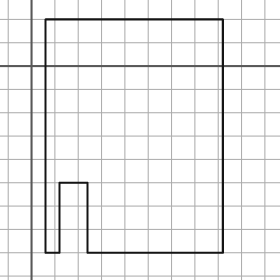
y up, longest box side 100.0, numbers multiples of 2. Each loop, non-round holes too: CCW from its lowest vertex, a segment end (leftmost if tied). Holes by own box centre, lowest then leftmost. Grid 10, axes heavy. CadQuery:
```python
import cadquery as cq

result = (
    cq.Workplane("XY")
    .moveTo(6.0, -80.0)
    .lineTo(12.0, -80.0)
    .lineTo(12.0, -50.0)
    .lineTo(24.0, -50.0)
    .lineTo(24.0, -80.0)
    .lineTo(82.0, -80.0)
    .lineTo(82.0, 20.0)
    .lineTo(6.0, 20.0)
    .close()
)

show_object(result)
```